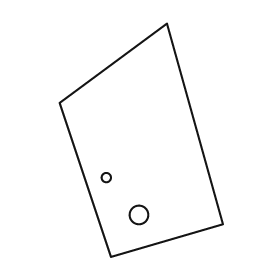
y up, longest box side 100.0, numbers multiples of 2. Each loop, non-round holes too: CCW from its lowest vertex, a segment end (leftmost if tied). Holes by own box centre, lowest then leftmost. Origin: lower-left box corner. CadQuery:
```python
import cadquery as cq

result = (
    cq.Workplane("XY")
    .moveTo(22.0, 0.0)
    .lineTo(70.0, 14.0)
    .lineTo(46.0, 100.0)
    .lineTo(0.0, 66.0)
    .close()
    .moveTo(34.0, 18.0)
    .circle(4.0)
    .moveTo(20.0, 34.0)
    .circle(2.0)
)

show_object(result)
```